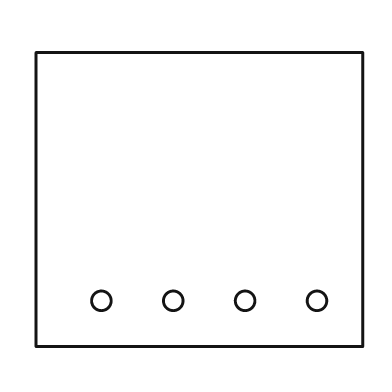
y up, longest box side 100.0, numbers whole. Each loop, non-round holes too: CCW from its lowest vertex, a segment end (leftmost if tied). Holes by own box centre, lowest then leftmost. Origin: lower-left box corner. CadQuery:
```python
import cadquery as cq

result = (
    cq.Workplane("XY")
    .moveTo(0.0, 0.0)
    .lineTo(100.0, 0.0)
    .lineTo(100.0, 90.0)
    .lineTo(0.0, 90.0)
    .close()
    .moveTo(20.0, 14.0)
    .circle(3.0)
    .moveTo(42.0, 14.0)
    .circle(3.0)
    .moveTo(64.0, 14.0)
    .circle(3.0)
    .moveTo(86.0, 14.0)
    .circle(3.0)
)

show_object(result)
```